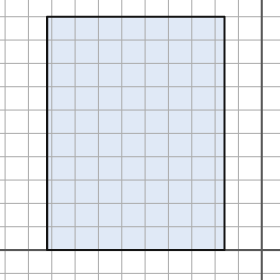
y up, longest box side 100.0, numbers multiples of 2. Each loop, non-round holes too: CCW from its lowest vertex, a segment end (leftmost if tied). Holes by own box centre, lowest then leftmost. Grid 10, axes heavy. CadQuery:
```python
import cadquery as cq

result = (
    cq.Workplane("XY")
    .moveTo(-92.0, 0.0)
    .lineTo(-16.0, 0.0)
    .lineTo(-16.0, 100.0)
    .lineTo(-92.0, 100.0)
    .close()
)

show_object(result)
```